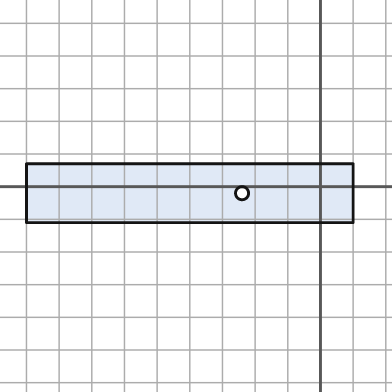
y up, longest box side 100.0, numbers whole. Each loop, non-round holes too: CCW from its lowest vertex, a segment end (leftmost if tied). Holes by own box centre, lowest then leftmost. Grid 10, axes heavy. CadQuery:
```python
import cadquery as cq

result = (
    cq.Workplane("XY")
    .moveTo(-90.0, -11.0)
    .lineTo(10.0, -11.0)
    .lineTo(10.0, 7.0)
    .lineTo(-90.0, 7.0)
    .close()
    .moveTo(-24.0, -2.0)
    .circle(2.0)
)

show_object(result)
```